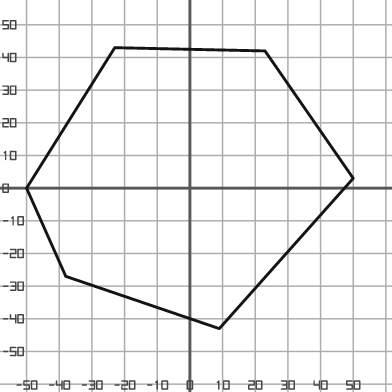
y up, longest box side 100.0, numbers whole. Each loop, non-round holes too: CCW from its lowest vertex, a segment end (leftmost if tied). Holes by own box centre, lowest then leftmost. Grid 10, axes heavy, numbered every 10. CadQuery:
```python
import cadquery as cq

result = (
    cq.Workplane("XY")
    .moveTo(9.0, -43.0)
    .lineTo(50.0, 3.0)
    .lineTo(23.0, 42.0)
    .lineTo(-23.0, 43.0)
    .lineTo(-50.0, 0.0)
    .lineTo(-38.0, -27.0)
    .close()
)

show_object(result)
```